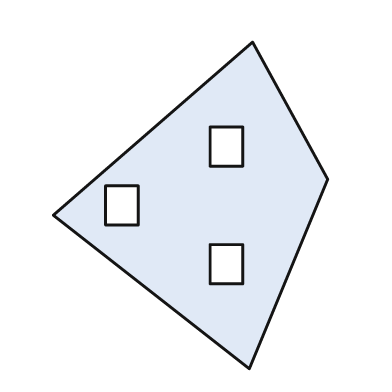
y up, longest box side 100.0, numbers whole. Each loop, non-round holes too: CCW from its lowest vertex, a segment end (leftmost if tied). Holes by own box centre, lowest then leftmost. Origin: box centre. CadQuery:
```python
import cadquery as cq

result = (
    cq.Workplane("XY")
    .moveTo(18.0, -50.0)
    .lineTo(42.0, 8.0)
    .lineTo(19.0, 50.0)
    .lineTo(-42.0, -3.0)
    .close()
    .moveTo(6.0, -24.0)
    .lineTo(16.0, -24.0)
    .lineTo(16.0, -12.0)
    .lineTo(6.0, -12.0)
    .close()
    .moveTo(-26.0, -6.0)
    .lineTo(-16.0, -6.0)
    .lineTo(-16.0, 6.0)
    .lineTo(-26.0, 6.0)
    .close()
    .moveTo(6.0, 12.0)
    .lineTo(16.0, 12.0)
    .lineTo(16.0, 24.0)
    .lineTo(6.0, 24.0)
    .close()
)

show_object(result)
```